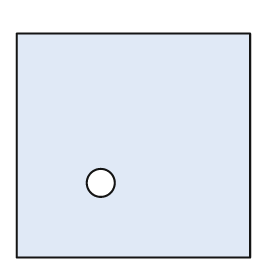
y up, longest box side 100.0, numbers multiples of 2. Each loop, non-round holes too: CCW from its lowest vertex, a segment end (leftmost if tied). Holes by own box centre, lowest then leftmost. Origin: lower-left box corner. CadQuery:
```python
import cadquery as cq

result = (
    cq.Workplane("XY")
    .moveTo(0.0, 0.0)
    .lineTo(100.0, 0.0)
    .lineTo(100.0, 96.0)
    .lineTo(0.0, 96.0)
    .close()
    .moveTo(36.0, 32.0)
    .circle(6.0)
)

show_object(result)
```